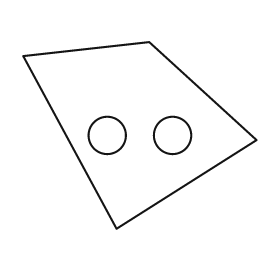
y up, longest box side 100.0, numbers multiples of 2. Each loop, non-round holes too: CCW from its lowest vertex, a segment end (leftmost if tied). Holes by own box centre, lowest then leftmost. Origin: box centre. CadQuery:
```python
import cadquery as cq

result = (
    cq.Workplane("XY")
    .moveTo(-10.0, -40.0)
    .lineTo(50.0, -2.0)
    .lineTo(4.0, 40.0)
    .lineTo(-50.0, 34.0)
    .close()
    .moveTo(-14.0, 0.0)
    .circle(8.0)
    .moveTo(14.0, 0.0)
    .circle(8.0)
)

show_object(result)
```